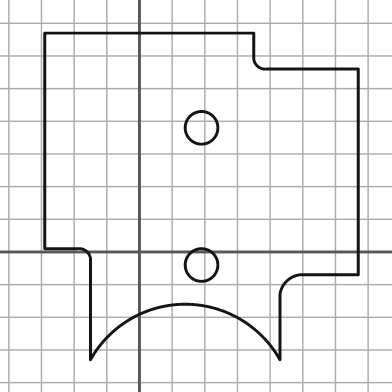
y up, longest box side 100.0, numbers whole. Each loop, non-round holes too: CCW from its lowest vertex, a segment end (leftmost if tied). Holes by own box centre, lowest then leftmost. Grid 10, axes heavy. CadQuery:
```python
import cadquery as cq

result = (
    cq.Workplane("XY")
    .moveTo(-15.0, -33.0)
    .threePointArc((14.0, -16.0), (43.0, -33.0))
    .lineTo(43.0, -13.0)
    .threePointArc((45.0, -9.0), (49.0, -7.0))
    .lineTo(67.0, -7.0)
    .lineTo(67.0, 56.0)
    .lineTo(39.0, 56.0)
    .threePointArc((36.0, 57.0), (35.0, 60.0))
    .lineTo(35.0, 67.0)
    .lineTo(-29.0, 67.0)
    .lineTo(-29.0, 1.0)
    .lineTo(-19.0, 1.0)
    .threePointArc((-16.0, 0.0), (-15.0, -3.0))
    .close()
    .moveTo(19.0, -4.0)
    .circle(5.0)
    .moveTo(19.0, 38.0)
    .circle(5.0)
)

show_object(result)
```